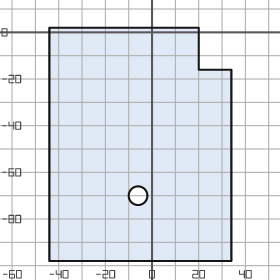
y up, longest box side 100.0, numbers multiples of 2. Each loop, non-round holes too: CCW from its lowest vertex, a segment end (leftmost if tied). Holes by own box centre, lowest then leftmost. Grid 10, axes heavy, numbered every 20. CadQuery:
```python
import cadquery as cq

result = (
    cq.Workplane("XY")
    .moveTo(-44.0, -98.0)
    .lineTo(34.0, -98.0)
    .lineTo(34.0, -16.0)
    .lineTo(20.0, -16.0)
    .lineTo(20.0, 2.0)
    .lineTo(-44.0, 2.0)
    .close()
    .moveTo(-6.0, -70.0)
    .circle(4.0)
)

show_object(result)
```